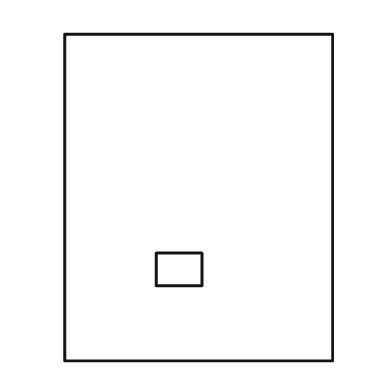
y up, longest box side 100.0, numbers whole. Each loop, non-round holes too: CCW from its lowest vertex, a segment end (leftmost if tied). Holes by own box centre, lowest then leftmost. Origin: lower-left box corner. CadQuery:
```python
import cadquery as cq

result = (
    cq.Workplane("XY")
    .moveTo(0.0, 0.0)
    .lineTo(82.0, 0.0)
    .lineTo(82.0, 100.0)
    .lineTo(0.0, 100.0)
    .close()
    .moveTo(28.0, 23.0)
    .lineTo(42.0, 23.0)
    .lineTo(42.0, 33.0)
    .lineTo(28.0, 33.0)
    .close()
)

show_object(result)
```